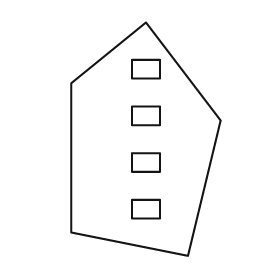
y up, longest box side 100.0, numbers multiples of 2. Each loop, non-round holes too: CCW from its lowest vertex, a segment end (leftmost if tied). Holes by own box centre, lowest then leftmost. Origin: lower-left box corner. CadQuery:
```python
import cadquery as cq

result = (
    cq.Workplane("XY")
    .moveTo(50.0, 0.0)
    .lineTo(64.0, 58.0)
    .lineTo(32.0, 100.0)
    .lineTo(0.0, 74.0)
    .lineTo(0.0, 10.0)
    .close()
    .moveTo(26.0, 16.0)
    .lineTo(38.0, 16.0)
    .lineTo(38.0, 24.0)
    .lineTo(26.0, 24.0)
    .close()
    .moveTo(26.0, 36.0)
    .lineTo(38.0, 36.0)
    .lineTo(38.0, 44.0)
    .lineTo(26.0, 44.0)
    .close()
    .moveTo(26.0, 56.0)
    .lineTo(38.0, 56.0)
    .lineTo(38.0, 64.0)
    .lineTo(26.0, 64.0)
    .close()
    .moveTo(26.0, 76.0)
    .lineTo(38.0, 76.0)
    .lineTo(38.0, 84.0)
    .lineTo(26.0, 84.0)
    .close()
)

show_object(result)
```